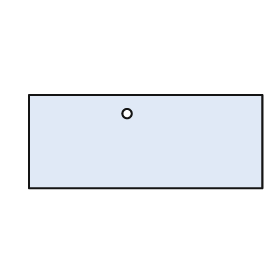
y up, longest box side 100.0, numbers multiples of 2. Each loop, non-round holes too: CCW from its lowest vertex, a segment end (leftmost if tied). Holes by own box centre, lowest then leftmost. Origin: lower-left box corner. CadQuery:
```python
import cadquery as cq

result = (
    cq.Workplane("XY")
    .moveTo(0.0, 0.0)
    .lineTo(100.0, 0.0)
    .lineTo(100.0, 40.0)
    .lineTo(0.0, 40.0)
    .close()
    .moveTo(42.0, 32.0)
    .circle(2.0)
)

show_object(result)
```